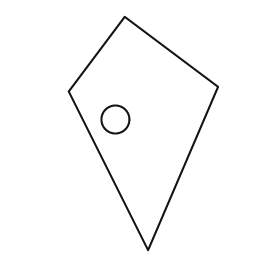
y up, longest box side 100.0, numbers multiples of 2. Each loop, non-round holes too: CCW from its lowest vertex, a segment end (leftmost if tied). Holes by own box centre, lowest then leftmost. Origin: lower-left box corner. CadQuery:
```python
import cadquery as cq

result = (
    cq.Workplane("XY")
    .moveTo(34.0, 0.0)
    .lineTo(64.0, 70.0)
    .lineTo(24.0, 100.0)
    .lineTo(0.0, 68.0)
    .close()
    .moveTo(20.0, 56.0)
    .circle(6.0)
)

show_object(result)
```